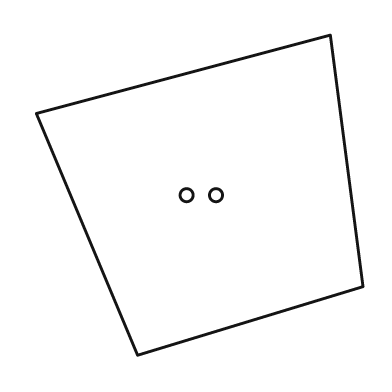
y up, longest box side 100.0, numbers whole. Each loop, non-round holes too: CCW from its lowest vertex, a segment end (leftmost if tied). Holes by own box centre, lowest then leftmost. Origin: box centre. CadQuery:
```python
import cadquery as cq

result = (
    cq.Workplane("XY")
    .moveTo(-19.0, -49.0)
    .lineTo(50.0, -28.0)
    .lineTo(40.0, 49.0)
    .lineTo(-50.0, 25.0)
    .close()
    .moveTo(-4.0, 0.0)
    .circle(2.0)
    .moveTo(5.0, 0.0)
    .circle(2.0)
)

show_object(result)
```